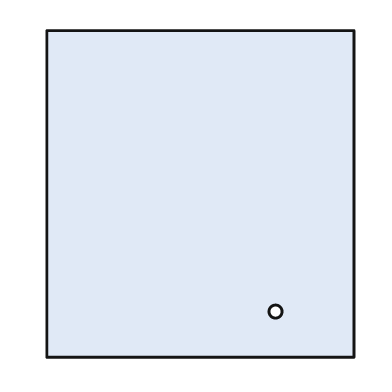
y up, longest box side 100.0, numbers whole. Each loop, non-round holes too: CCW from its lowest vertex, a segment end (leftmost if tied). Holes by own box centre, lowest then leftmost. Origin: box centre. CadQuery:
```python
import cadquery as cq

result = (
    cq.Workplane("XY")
    .moveTo(-47.0, -50.0)
    .lineTo(47.0, -50.0)
    .lineTo(47.0, 50.0)
    .lineTo(-47.0, 50.0)
    .close()
    .moveTo(23.0, -36.0)
    .circle(2.0)
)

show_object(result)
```